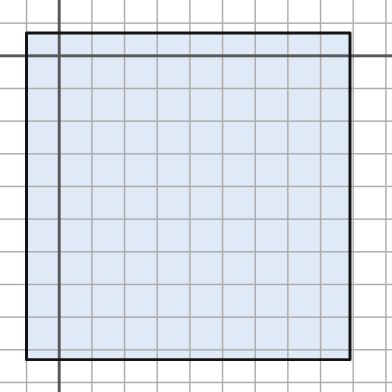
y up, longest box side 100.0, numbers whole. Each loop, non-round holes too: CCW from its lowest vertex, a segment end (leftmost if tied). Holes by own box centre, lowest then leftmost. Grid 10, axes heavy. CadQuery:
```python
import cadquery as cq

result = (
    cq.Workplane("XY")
    .moveTo(-10.0, -93.0)
    .lineTo(89.0, -93.0)
    .lineTo(89.0, 7.0)
    .lineTo(-10.0, 7.0)
    .close()
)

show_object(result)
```